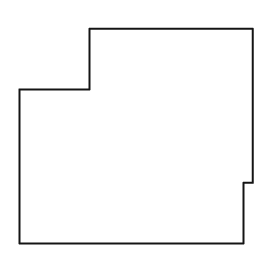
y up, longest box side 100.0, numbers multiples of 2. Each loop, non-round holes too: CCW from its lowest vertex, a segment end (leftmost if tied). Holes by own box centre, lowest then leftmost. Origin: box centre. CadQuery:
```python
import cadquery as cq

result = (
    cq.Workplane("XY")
    .moveTo(-50.0, -46.0)
    .lineTo(46.0, -46.0)
    .lineTo(46.0, -20.0)
    .lineTo(50.0, -20.0)
    .lineTo(50.0, 46.0)
    .lineTo(-20.0, 46.0)
    .lineTo(-20.0, 20.0)
    .lineTo(-50.0, 20.0)
    .close()
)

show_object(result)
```